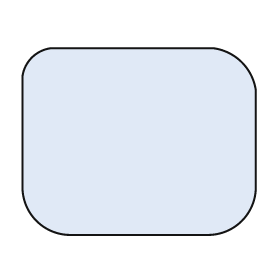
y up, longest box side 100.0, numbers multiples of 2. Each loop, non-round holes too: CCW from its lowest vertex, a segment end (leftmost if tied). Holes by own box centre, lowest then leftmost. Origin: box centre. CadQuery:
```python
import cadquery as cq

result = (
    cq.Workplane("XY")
    .moveTo(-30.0, -40.0)
    .lineTo(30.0, -40.0)
    .threePointArc((44.0, -34.0), (50.0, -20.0))
    .lineTo(50.0, 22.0)
    .threePointArc((44.0, 34.0), (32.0, 40.0))
    .lineTo(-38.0, 40.0)
    .threePointArc((-46.0, 36.0), (-50.0, 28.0))
    .lineTo(-50.0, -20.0)
    .threePointArc((-44.0, -34.0), (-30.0, -40.0))
    .close()
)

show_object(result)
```